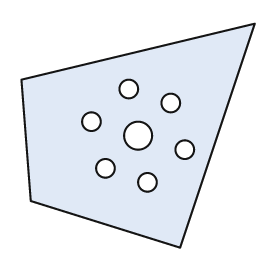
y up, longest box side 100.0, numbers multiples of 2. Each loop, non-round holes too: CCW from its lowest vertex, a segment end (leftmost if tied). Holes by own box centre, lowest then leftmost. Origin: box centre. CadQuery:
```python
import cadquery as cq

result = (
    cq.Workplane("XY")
    .moveTo(18.0, -48.0)
    .lineTo(50.0, 48.0)
    .lineTo(-50.0, 24.0)
    .lineTo(-46.0, -28.0)
    .close()
    .moveTo(4.0, -20.0)
    .circle(4.0)
    .moveTo(-14.0, -14.0)
    .circle(4.0)
    .moveTo(20.0, -6.0)
    .circle(4.0)
    .moveTo(0.0, 0.0)
    .circle(6.0)
    .moveTo(-20.0, 6.0)
    .circle(4.0)
    .moveTo(14.0, 14.0)
    .circle(4.0)
    .moveTo(-4.0, 20.0)
    .circle(4.0)
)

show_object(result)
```